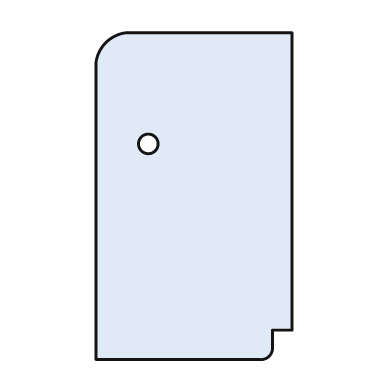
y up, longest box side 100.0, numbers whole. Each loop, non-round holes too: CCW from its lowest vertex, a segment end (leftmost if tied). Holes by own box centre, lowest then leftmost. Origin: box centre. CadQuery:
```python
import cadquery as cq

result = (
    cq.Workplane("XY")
    .moveTo(-30.0, -50.0)
    .lineTo(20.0, -50.0)
    .threePointArc((23.0, -49.0), (24.0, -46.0))
    .lineTo(24.0, -41.0)
    .lineTo(30.0, -41.0)
    .lineTo(30.0, 50.0)
    .lineTo(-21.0, 50.0)
    .threePointArc((-27.0, 47.0), (-30.0, 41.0))
    .close()
    .moveTo(-14.0, 16.0)
    .circle(3.0)
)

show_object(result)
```